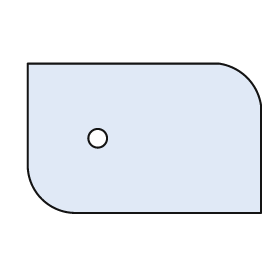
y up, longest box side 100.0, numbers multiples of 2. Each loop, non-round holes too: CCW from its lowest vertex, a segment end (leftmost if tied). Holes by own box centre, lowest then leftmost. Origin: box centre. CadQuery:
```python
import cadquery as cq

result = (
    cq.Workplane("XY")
    .moveTo(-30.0, -32.0)
    .lineTo(50.0, -32.0)
    .lineTo(50.0, 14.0)
    .threePointArc((44.0, 26.0), (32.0, 32.0))
    .lineTo(-50.0, 32.0)
    .lineTo(-50.0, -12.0)
    .threePointArc((-44.0, -26.0), (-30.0, -32.0))
    .close()
    .moveTo(-20.0, 0.0)
    .circle(4.0)
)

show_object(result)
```